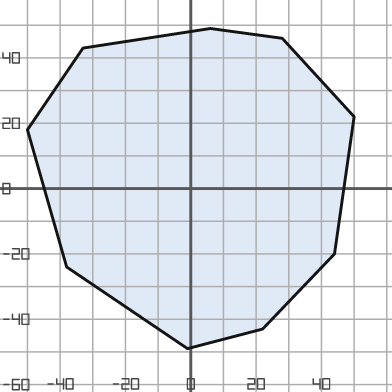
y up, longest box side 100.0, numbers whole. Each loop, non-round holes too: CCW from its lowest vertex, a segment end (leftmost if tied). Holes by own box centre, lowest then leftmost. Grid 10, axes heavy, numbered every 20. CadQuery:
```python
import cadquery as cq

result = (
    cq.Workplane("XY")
    .moveTo(-1.0, -49.0)
    .lineTo(22.0, -43.0)
    .lineTo(44.0, -20.0)
    .lineTo(50.0, 22.0)
    .lineTo(28.0, 46.0)
    .lineTo(6.0, 49.0)
    .lineTo(-33.0, 43.0)
    .lineTo(-50.0, 18.0)
    .lineTo(-38.0, -24.0)
    .close()
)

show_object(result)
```